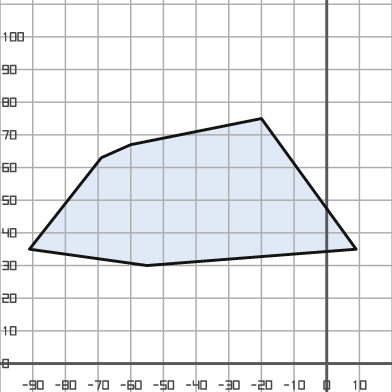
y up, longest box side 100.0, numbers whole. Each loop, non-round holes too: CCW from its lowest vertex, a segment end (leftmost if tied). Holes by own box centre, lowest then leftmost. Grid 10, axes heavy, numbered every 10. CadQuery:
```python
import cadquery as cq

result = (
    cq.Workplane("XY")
    .moveTo(-55.0, 30.0)
    .lineTo(9.0, 35.0)
    .lineTo(-20.0, 75.0)
    .lineTo(-60.0, 67.0)
    .lineTo(-69.0, 63.0)
    .lineTo(-91.0, 35.0)
    .close()
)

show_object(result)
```